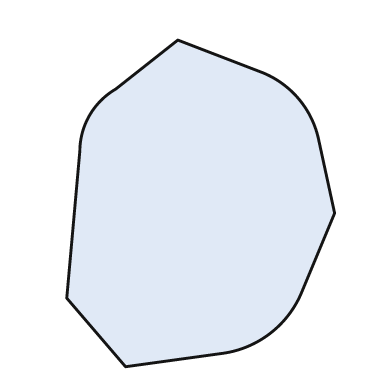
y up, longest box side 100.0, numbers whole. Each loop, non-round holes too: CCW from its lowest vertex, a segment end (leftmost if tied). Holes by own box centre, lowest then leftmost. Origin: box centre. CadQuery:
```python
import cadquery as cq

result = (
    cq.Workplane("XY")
    .moveTo(-23.0, -50.0)
    .lineTo(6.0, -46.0)
    .threePointArc((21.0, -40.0), (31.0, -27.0))
    .lineTo(41.0, -3.0)
    .lineTo(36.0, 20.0)
    .threePointArc((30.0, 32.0), (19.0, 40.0))
    .lineTo(-7.0, 50.0)
    .lineTo(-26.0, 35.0)
    .threePointArc((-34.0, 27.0), (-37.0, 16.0))
    .lineTo(-41.0, -29.0)
    .close()
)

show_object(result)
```